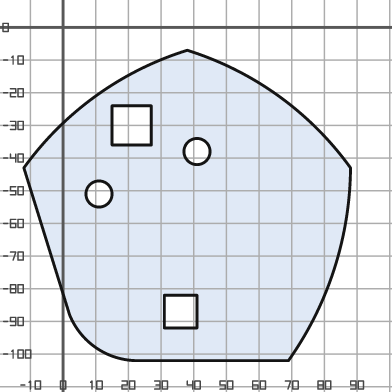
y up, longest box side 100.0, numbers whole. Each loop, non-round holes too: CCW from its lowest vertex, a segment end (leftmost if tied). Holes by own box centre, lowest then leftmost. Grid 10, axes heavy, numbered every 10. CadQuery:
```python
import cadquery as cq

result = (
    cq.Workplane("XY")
    .moveTo(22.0, -102.0)
    .lineTo(69.0, -102.0)
    .threePointArc((83.0, -74.0), (88.0, -43.0))
    .threePointArc((66.0, -21.0), (38.0, -7.0))
    .threePointArc((10.0, -21.0), (-12.0, -43.0))
    .lineTo(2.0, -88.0)
    .threePointArc((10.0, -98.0), (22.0, -102.0))
    .close()
    .moveTo(31.0, -92.0)
    .lineTo(41.0, -92.0)
    .lineTo(41.0, -82.0)
    .lineTo(31.0, -82.0)
    .close()
    .moveTo(11.0, -51.0)
    .circle(4.0)
    .moveTo(41.0, -38.0)
    .circle(4.0)
    .moveTo(15.0, -36.0)
    .lineTo(27.0, -36.0)
    .lineTo(27.0, -24.0)
    .lineTo(15.0, -24.0)
    .close()
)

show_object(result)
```